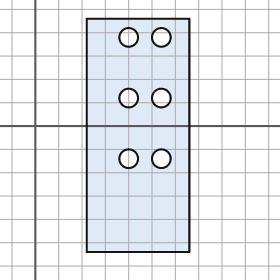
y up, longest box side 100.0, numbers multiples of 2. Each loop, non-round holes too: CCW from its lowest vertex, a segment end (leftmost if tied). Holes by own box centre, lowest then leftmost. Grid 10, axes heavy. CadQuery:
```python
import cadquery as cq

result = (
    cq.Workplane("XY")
    .moveTo(22.0, -54.0)
    .lineTo(66.0, -54.0)
    .lineTo(66.0, 46.0)
    .lineTo(22.0, 46.0)
    .close()
    .moveTo(40.0, -14.0)
    .circle(4.0)
    .moveTo(54.0, -14.0)
    .circle(4.0)
    .moveTo(40.0, 12.0)
    .circle(4.0)
    .moveTo(54.0, 12.0)
    .circle(4.0)
    .moveTo(40.0, 38.0)
    .circle(4.0)
    .moveTo(54.0, 38.0)
    .circle(4.0)
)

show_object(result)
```